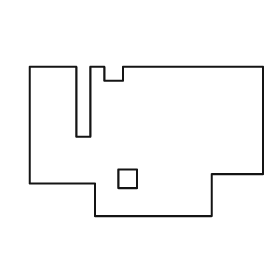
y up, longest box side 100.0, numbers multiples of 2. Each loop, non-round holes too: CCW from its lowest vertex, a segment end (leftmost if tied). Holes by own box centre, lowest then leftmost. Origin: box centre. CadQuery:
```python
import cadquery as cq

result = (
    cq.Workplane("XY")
    .moveTo(-22.0, -32.0)
    .lineTo(28.0, -32.0)
    .lineTo(28.0, -14.0)
    .lineTo(50.0, -14.0)
    .lineTo(50.0, 32.0)
    .lineTo(-10.0, 32.0)
    .lineTo(-10.0, 26.0)
    .lineTo(-18.0, 26.0)
    .lineTo(-18.0, 32.0)
    .lineTo(-24.0, 32.0)
    .lineTo(-24.0, 2.0)
    .lineTo(-30.0, 2.0)
    .lineTo(-30.0, 32.0)
    .lineTo(-50.0, 32.0)
    .lineTo(-50.0, -18.0)
    .lineTo(-22.0, -18.0)
    .close()
    .moveTo(-12.0, -20.0)
    .lineTo(-4.0, -20.0)
    .lineTo(-4.0, -12.0)
    .lineTo(-12.0, -12.0)
    .close()
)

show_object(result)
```